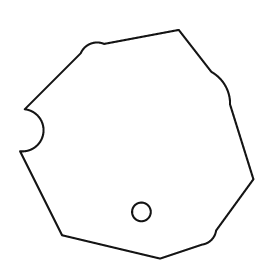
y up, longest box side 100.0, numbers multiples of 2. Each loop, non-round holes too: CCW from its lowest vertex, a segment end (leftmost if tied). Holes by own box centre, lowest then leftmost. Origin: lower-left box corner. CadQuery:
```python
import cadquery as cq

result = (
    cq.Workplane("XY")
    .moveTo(60.0, 0.0)
    .lineTo(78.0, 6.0)
    .threePointArc((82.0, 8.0), (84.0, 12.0))
    .lineTo(100.0, 34.0)
    .lineTo(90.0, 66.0)
    .threePointArc((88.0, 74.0), (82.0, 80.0))
    .lineTo(68.0, 98.0)
    .lineTo(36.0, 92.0)
    .threePointArc((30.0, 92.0), (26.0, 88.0))
    .lineTo(2.0, 64.0)
    .threePointArc((10.0, 54.0), (0.0, 46.0))
    .lineTo(18.0, 10.0)
    .close()
    .moveTo(52.0, 20.0)
    .circle(4.0)
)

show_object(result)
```